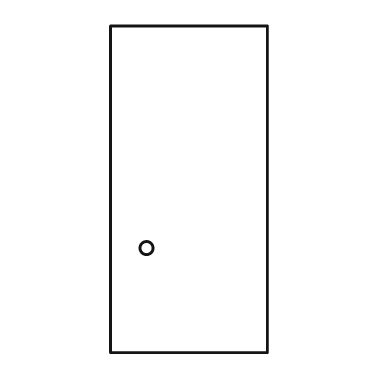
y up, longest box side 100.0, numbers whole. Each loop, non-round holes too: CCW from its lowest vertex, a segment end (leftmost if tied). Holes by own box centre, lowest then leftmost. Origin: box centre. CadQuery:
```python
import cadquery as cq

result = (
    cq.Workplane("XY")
    .moveTo(-24.0, -50.0)
    .lineTo(24.0, -50.0)
    .lineTo(24.0, 50.0)
    .lineTo(-24.0, 50.0)
    .close()
    .moveTo(-13.0, -18.0)
    .circle(2.0)
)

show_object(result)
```